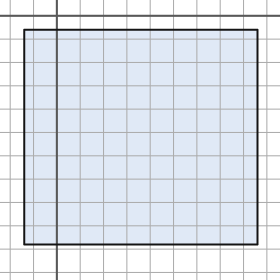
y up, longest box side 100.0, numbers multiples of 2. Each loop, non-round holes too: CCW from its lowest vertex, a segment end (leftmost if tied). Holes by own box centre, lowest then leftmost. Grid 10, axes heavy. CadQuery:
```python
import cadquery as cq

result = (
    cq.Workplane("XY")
    .moveTo(-14.0, -98.0)
    .lineTo(86.0, -98.0)
    .lineTo(86.0, -6.0)
    .lineTo(-14.0, -6.0)
    .close()
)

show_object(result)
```